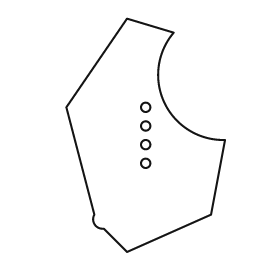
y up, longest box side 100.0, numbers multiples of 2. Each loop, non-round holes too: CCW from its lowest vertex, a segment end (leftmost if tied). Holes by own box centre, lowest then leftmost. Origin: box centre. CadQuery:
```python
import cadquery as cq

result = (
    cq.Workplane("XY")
    .moveTo(-8.0, -50.0)
    .lineTo(28.0, -34.0)
    .lineTo(34.0, -2.0)
    .threePointArc((8.0, 14.0), (12.0, 44.0))
    .lineTo(-8.0, 50.0)
    .lineTo(-34.0, 12.0)
    .lineTo(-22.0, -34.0)
    .threePointArc((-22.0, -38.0), (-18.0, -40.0))
    .close()
    .moveTo(0.0, -12.0)
    .circle(2.0)
    .moveTo(0.0, -4.0)
    .circle(2.0)
    .moveTo(0.0, 4.0)
    .circle(2.0)
    .moveTo(0.0, 12.0)
    .circle(2.0)
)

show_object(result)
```